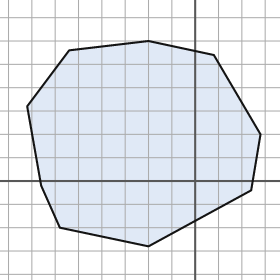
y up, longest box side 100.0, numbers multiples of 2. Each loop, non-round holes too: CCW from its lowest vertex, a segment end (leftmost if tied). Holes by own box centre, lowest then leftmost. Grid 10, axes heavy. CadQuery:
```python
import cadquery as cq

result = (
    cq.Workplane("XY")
    .moveTo(-20.0, -28.0)
    .lineTo(24.0, -4.0)
    .lineTo(28.0, 20.0)
    .lineTo(8.0, 54.0)
    .lineTo(-20.0, 60.0)
    .lineTo(-54.0, 56.0)
    .lineTo(-72.0, 32.0)
    .lineTo(-66.0, -2.0)
    .lineTo(-58.0, -20.0)
    .close()
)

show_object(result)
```